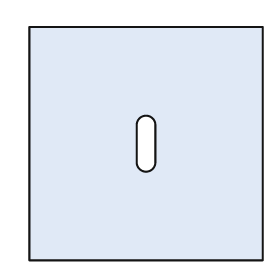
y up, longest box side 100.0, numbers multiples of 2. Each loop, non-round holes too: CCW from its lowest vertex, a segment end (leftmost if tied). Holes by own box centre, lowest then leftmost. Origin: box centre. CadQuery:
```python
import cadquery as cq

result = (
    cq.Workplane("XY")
    .moveTo(-50.0, -50.0)
    .lineTo(50.0, -50.0)
    .lineTo(50.0, 50.0)
    .lineTo(-50.0, 50.0)
    .close()
    .moveTo(-4.0, -8.0)
    .threePointArc((0.0, -12.0), (4.0, -8.0))
    .lineTo(4.0, 8.0)
    .threePointArc((0.0, 12.0), (-4.0, 8.0))
    .close()
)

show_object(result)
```